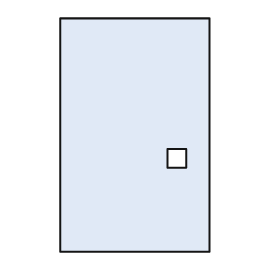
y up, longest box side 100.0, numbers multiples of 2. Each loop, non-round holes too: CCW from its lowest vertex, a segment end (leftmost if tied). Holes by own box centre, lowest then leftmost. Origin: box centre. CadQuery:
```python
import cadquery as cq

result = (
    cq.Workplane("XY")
    .moveTo(-32.0, -50.0)
    .lineTo(32.0, -50.0)
    .lineTo(32.0, 50.0)
    .lineTo(-32.0, 50.0)
    .close()
    .moveTo(14.0, -14.0)
    .lineTo(22.0, -14.0)
    .lineTo(22.0, -6.0)
    .lineTo(14.0, -6.0)
    .close()
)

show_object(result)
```